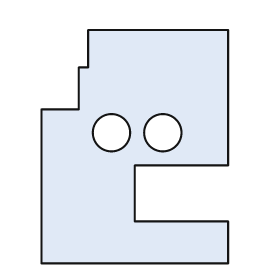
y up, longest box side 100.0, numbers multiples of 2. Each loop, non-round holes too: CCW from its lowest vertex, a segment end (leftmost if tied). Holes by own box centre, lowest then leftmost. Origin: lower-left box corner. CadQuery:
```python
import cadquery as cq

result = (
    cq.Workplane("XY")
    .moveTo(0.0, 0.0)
    .lineTo(80.0, 0.0)
    .lineTo(80.0, 18.0)
    .lineTo(40.0, 18.0)
    .lineTo(40.0, 42.0)
    .lineTo(80.0, 42.0)
    .lineTo(80.0, 100.0)
    .lineTo(20.0, 100.0)
    .lineTo(20.0, 84.0)
    .lineTo(16.0, 84.0)
    .lineTo(16.0, 66.0)
    .lineTo(0.0, 66.0)
    .close()
    .moveTo(30.0, 56.0)
    .circle(8.0)
    .moveTo(52.0, 56.0)
    .circle(8.0)
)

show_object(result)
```